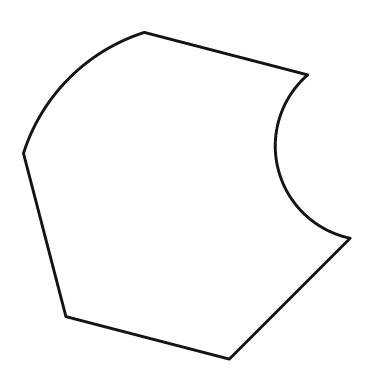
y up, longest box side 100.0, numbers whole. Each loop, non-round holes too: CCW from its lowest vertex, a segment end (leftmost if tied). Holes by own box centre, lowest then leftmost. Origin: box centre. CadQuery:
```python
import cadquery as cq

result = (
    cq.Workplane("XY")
    .moveTo(13.0, -50.0)
    .lineTo(50.0, -13.0)
    .threePointArc((28.0, 8.0), (37.0, 37.0))
    .lineTo(-13.0, 50.0)
    .threePointArc((-36.0, 36.0), (-50.0, 13.0))
    .lineTo(-37.0, -37.0)
    .close()
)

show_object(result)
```